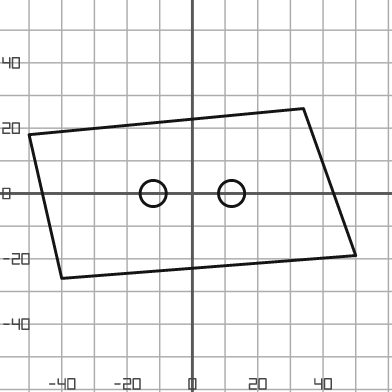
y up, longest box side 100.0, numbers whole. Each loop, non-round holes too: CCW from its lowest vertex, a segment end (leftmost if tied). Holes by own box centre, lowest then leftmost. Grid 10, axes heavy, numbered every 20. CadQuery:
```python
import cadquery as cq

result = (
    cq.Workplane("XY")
    .moveTo(-40.0, -26.0)
    .lineTo(50.0, -19.0)
    .lineTo(34.0, 26.0)
    .lineTo(-50.0, 18.0)
    .close()
    .moveTo(-12.0, 0.0)
    .circle(4.0)
    .moveTo(12.0, 0.0)
    .circle(4.0)
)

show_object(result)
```